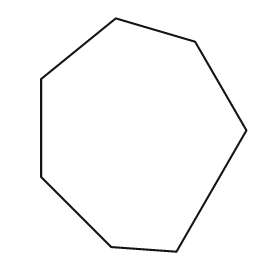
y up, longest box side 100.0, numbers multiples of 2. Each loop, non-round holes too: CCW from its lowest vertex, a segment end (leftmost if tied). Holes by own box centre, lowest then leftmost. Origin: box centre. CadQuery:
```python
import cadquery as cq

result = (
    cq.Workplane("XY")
    .moveTo(14.0, -50.0)
    .lineTo(44.0, 2.0)
    .lineTo(22.0, 40.0)
    .lineTo(-12.0, 50.0)
    .lineTo(-44.0, 24.0)
    .lineTo(-44.0, -18.0)
    .lineTo(-14.0, -48.0)
    .close()
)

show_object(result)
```